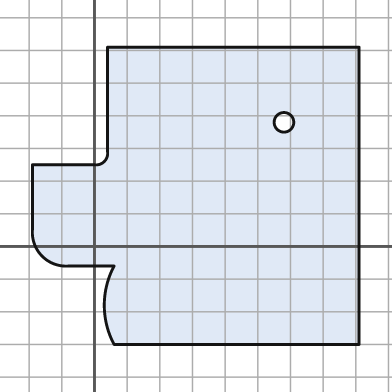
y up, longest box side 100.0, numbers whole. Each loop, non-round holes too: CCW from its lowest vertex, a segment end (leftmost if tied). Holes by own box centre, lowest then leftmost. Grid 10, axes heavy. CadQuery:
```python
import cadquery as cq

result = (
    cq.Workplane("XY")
    .moveTo(6.0, -30.0)
    .lineTo(81.0, -30.0)
    .lineTo(81.0, 61.0)
    .lineTo(4.0, 61.0)
    .lineTo(4.0, 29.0)
    .threePointArc((3.0, 26.0), (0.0, 25.0))
    .lineTo(-19.0, 25.0)
    .lineTo(-19.0, 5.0)
    .threePointArc((-16.0, -3.0), (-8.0, -6.0))
    .lineTo(6.0, -6.0)
    .threePointArc((3.0, -18.0), (6.0, -30.0))
    .close()
    .moveTo(58.0, 38.0)
    .circle(3.0)
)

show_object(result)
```